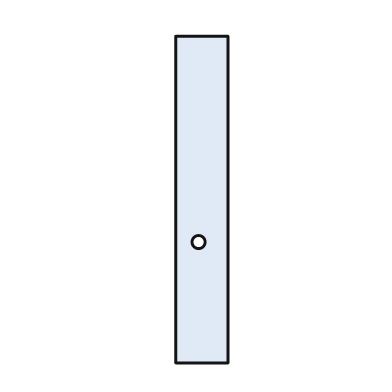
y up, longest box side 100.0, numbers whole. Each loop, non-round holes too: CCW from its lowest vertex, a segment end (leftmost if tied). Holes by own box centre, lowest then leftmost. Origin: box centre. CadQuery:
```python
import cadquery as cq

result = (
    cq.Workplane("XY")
    .moveTo(-8.0, -50.0)
    .lineTo(8.0, -50.0)
    .lineTo(8.0, 50.0)
    .lineTo(-8.0, 50.0)
    .close()
    .moveTo(-1.0, -13.0)
    .circle(2.0)
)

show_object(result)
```